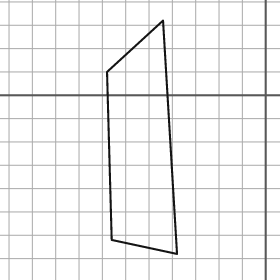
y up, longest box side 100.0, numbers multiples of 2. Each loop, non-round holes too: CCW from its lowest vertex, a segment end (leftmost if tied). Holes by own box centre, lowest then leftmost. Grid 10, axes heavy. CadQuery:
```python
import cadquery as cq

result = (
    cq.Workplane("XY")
    .moveTo(-38.0, -68.0)
    .lineTo(-44.0, 32.0)
    .lineTo(-68.0, 10.0)
    .lineTo(-66.0, -62.0)
    .close()
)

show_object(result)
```